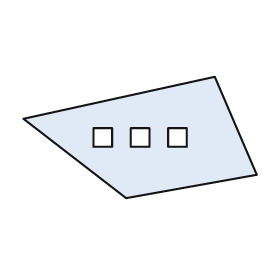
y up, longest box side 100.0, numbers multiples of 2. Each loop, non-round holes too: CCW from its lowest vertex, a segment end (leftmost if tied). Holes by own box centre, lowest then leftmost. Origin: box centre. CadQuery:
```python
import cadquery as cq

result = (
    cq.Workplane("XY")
    .moveTo(-6.0, -26.0)
    .lineTo(50.0, -16.0)
    .lineTo(32.0, 26.0)
    .lineTo(-50.0, 8.0)
    .close()
    .moveTo(-20.0, -4.0)
    .lineTo(-12.0, -4.0)
    .lineTo(-12.0, 4.0)
    .lineTo(-20.0, 4.0)
    .close()
    .moveTo(-4.0, -4.0)
    .lineTo(4.0, -4.0)
    .lineTo(4.0, 4.0)
    .lineTo(-4.0, 4.0)
    .close()
    .moveTo(12.0, -4.0)
    .lineTo(20.0, -4.0)
    .lineTo(20.0, 4.0)
    .lineTo(12.0, 4.0)
    .close()
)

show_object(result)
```